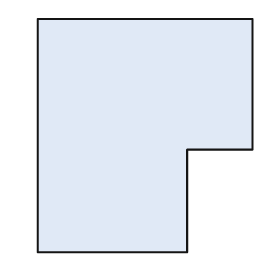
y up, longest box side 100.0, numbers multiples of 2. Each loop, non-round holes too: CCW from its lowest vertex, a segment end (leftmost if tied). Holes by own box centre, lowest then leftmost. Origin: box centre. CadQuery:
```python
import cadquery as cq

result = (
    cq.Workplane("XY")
    .moveTo(-46.0, -50.0)
    .lineTo(18.0, -50.0)
    .lineTo(18.0, -6.0)
    .lineTo(46.0, -6.0)
    .lineTo(46.0, 50.0)
    .lineTo(-46.0, 50.0)
    .close()
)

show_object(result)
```